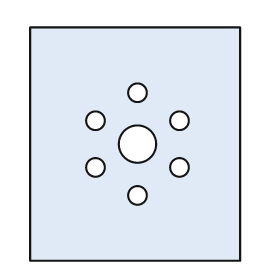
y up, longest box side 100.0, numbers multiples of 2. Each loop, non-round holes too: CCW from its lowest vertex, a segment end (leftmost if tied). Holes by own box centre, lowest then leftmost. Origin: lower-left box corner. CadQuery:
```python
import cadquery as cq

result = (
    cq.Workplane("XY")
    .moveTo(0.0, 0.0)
    .lineTo(90.0, 0.0)
    .lineTo(90.0, 100.0)
    .lineTo(0.0, 100.0)
    .close()
    .moveTo(46.0, 28.0)
    .circle(4.0)
    .moveTo(28.0, 40.0)
    .circle(4.0)
    .moveTo(64.0, 40.0)
    .circle(4.0)
    .moveTo(46.0, 50.0)
    .circle(8.0)
    .moveTo(28.0, 60.0)
    .circle(4.0)
    .moveTo(64.0, 60.0)
    .circle(4.0)
    .moveTo(46.0, 72.0)
    .circle(4.0)
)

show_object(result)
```